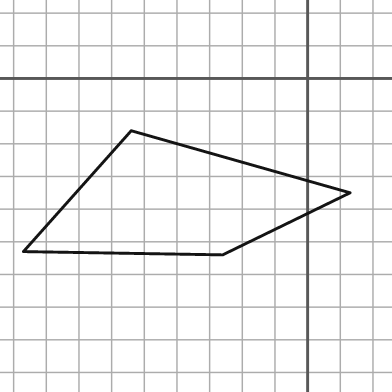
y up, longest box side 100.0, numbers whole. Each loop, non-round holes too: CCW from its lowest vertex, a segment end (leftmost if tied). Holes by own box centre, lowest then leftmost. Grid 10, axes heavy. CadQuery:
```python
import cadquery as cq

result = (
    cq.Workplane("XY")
    .moveTo(-26.0, -54.0)
    .lineTo(13.0, -35.0)
    .lineTo(-54.0, -16.0)
    .lineTo(-87.0, -53.0)
    .close()
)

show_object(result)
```